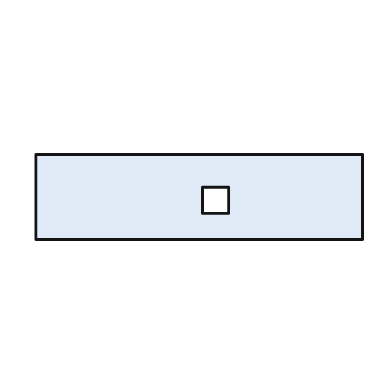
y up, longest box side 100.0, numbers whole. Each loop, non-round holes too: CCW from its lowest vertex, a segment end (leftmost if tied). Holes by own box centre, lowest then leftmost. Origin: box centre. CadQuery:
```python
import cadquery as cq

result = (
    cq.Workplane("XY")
    .moveTo(-50.0, -13.0)
    .lineTo(50.0, -13.0)
    .lineTo(50.0, 13.0)
    .lineTo(-50.0, 13.0)
    .close()
    .moveTo(1.0, -5.0)
    .lineTo(9.0, -5.0)
    .lineTo(9.0, 3.0)
    .lineTo(1.0, 3.0)
    .close()
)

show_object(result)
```